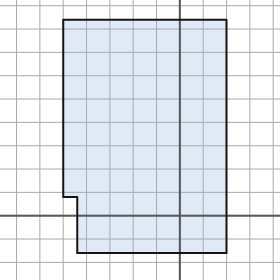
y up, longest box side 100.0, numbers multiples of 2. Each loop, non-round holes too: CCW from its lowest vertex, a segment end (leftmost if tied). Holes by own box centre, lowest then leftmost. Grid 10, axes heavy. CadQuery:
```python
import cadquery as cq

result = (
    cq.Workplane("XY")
    .moveTo(-44.0, -16.0)
    .lineTo(20.0, -16.0)
    .lineTo(20.0, 84.0)
    .lineTo(-50.0, 84.0)
    .lineTo(-50.0, 8.0)
    .lineTo(-44.0, 8.0)
    .close()
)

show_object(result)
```